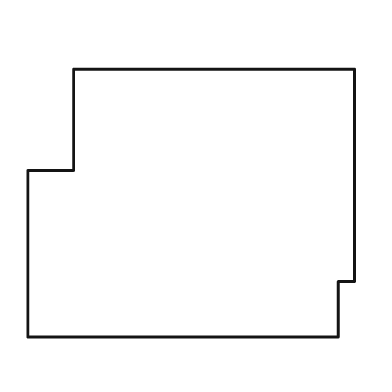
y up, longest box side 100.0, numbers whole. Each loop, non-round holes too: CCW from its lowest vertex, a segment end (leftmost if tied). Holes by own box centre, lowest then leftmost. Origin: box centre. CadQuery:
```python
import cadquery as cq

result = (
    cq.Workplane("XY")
    .moveTo(-50.0, -41.0)
    .lineTo(45.0, -41.0)
    .lineTo(45.0, -24.0)
    .lineTo(50.0, -24.0)
    .lineTo(50.0, 41.0)
    .lineTo(-36.0, 41.0)
    .lineTo(-36.0, 10.0)
    .lineTo(-50.0, 10.0)
    .close()
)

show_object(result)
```